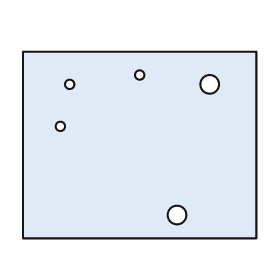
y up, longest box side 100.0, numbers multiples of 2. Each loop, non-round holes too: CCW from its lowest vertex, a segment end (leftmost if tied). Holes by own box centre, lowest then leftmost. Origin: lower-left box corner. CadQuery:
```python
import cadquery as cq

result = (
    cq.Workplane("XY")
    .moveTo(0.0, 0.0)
    .lineTo(100.0, 0.0)
    .lineTo(100.0, 80.0)
    .lineTo(0.0, 80.0)
    .close()
    .moveTo(66.0, 10.0)
    .circle(4.0)
    .moveTo(16.0, 48.0)
    .circle(2.0)
    .moveTo(20.0, 66.0)
    .circle(2.0)
    .moveTo(80.0, 66.0)
    .circle(4.0)
    .moveTo(50.0, 70.0)
    .circle(2.0)
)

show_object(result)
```